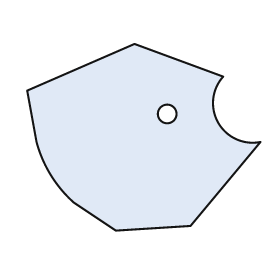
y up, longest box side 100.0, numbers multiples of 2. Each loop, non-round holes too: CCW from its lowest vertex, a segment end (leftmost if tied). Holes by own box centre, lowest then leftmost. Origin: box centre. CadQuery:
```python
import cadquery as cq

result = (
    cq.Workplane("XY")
    .moveTo(-12.0, -40.0)
    .lineTo(20.0, -38.0)
    .lineTo(50.0, -2.0)
    .threePointArc((32.0, 6.0), (34.0, 26.0))
    .lineTo(-4.0, 40.0)
    .lineTo(-50.0, 20.0)
    .lineTo(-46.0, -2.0)
    .threePointArc((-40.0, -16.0), (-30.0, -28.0))
    .close()
    .moveTo(10.0, 10.0)
    .circle(4.0)
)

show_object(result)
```